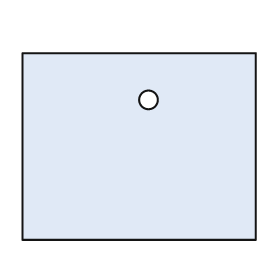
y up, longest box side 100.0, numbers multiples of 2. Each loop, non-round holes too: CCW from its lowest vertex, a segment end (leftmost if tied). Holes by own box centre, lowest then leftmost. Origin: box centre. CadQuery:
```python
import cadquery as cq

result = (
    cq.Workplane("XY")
    .moveTo(-50.0, -40.0)
    .lineTo(50.0, -40.0)
    .lineTo(50.0, 40.0)
    .lineTo(-50.0, 40.0)
    .close()
    .moveTo(4.0, 20.0)
    .circle(4.0)
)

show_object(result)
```